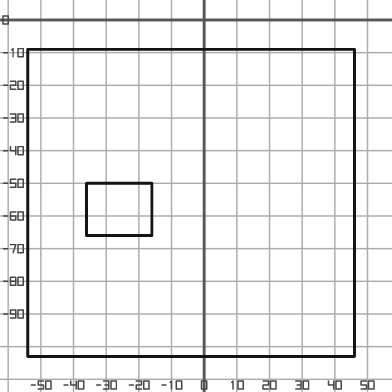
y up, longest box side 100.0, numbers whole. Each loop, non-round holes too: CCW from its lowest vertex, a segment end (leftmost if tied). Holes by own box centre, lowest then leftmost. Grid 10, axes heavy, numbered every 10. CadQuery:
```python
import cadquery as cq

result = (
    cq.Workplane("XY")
    .moveTo(-54.0, -103.0)
    .lineTo(46.0, -103.0)
    .lineTo(46.0, -9.0)
    .lineTo(-54.0, -9.0)
    .close()
    .moveTo(-36.0, -66.0)
    .lineTo(-16.0, -66.0)
    .lineTo(-16.0, -50.0)
    .lineTo(-36.0, -50.0)
    .close()
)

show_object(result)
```